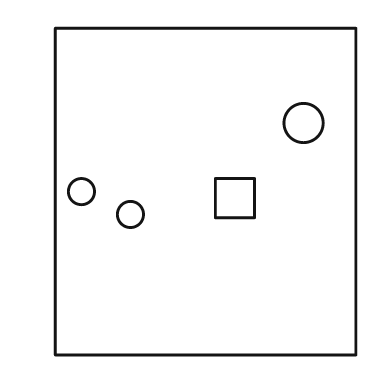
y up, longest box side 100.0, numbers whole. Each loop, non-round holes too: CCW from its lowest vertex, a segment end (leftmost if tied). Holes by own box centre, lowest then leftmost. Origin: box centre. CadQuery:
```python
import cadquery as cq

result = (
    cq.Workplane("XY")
    .moveTo(-46.0, -50.0)
    .lineTo(46.0, -50.0)
    .lineTo(46.0, 50.0)
    .lineTo(-46.0, 50.0)
    .close()
    .moveTo(-23.0, -7.0)
    .circle(4.0)
    .moveTo(3.0, -8.0)
    .lineTo(15.0, -8.0)
    .lineTo(15.0, 4.0)
    .lineTo(3.0, 4.0)
    .close()
    .moveTo(-38.0, 0.0)
    .circle(4.0)
    .moveTo(30.0, 21.0)
    .circle(6.0)
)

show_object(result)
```